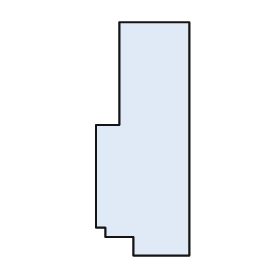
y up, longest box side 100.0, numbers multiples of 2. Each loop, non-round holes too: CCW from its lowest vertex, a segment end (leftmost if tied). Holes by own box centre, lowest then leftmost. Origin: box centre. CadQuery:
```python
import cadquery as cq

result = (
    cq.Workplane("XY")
    .moveTo(-4.0, -50.0)
    .lineTo(20.0, -50.0)
    .lineTo(20.0, 50.0)
    .lineTo(-10.0, 50.0)
    .lineTo(-10.0, 6.0)
    .lineTo(-20.0, 6.0)
    .lineTo(-20.0, -38.0)
    .lineTo(-16.0, -38.0)
    .lineTo(-16.0, -42.0)
    .lineTo(-4.0, -42.0)
    .close()
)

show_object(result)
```